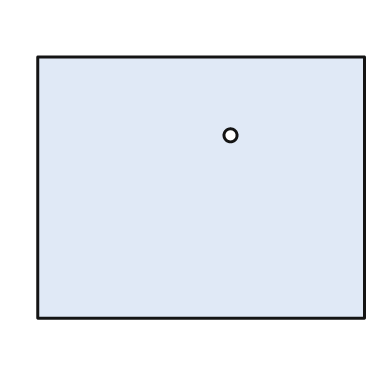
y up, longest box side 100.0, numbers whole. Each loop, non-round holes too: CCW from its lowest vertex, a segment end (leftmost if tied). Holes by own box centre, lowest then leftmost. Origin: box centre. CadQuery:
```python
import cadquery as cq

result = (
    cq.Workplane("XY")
    .moveTo(-50.0, -40.0)
    .lineTo(50.0, -40.0)
    .lineTo(50.0, 40.0)
    .lineTo(-50.0, 40.0)
    .close()
    .moveTo(9.0, 16.0)
    .circle(2.0)
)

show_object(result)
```